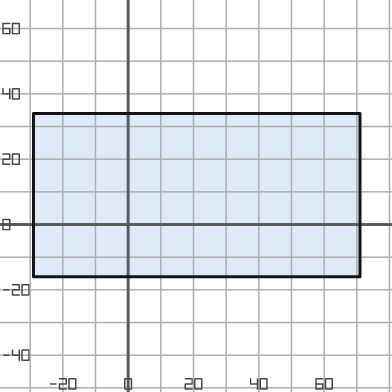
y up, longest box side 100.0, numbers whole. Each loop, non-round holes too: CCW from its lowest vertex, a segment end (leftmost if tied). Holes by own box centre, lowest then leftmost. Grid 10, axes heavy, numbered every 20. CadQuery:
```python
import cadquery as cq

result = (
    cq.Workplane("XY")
    .moveTo(-29.0, -16.0)
    .lineTo(71.0, -16.0)
    .lineTo(71.0, 34.0)
    .lineTo(-29.0, 34.0)
    .close()
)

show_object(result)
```